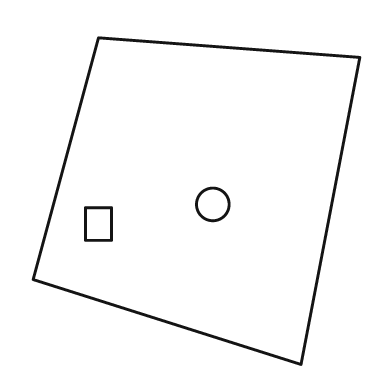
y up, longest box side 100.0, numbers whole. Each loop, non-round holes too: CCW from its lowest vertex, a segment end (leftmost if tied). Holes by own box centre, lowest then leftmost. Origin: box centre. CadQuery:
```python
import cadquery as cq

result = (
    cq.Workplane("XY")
    .moveTo(32.0, -50.0)
    .lineTo(50.0, 44.0)
    .lineTo(-30.0, 50.0)
    .lineTo(-50.0, -24.0)
    .close()
    .moveTo(-34.0, -12.0)
    .lineTo(-26.0, -12.0)
    .lineTo(-26.0, -2.0)
    .lineTo(-34.0, -2.0)
    .close()
    .moveTo(5.0, -1.0)
    .circle(5.0)
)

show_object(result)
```